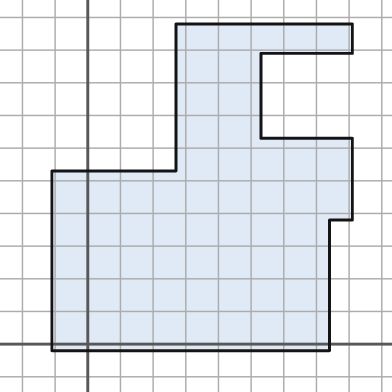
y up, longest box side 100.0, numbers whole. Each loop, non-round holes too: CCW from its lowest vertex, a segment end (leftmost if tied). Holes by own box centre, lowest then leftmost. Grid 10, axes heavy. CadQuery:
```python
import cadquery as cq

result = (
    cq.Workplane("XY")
    .moveTo(-11.0, -2.0)
    .lineTo(74.0, -2.0)
    .lineTo(74.0, 38.0)
    .lineTo(81.0, 38.0)
    .lineTo(81.0, 63.0)
    .lineTo(53.0, 63.0)
    .lineTo(53.0, 89.0)
    .lineTo(81.0, 89.0)
    .lineTo(81.0, 98.0)
    .lineTo(27.0, 98.0)
    .lineTo(27.0, 53.0)
    .lineTo(-11.0, 53.0)
    .close()
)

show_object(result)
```